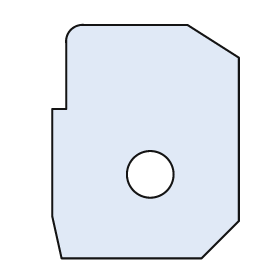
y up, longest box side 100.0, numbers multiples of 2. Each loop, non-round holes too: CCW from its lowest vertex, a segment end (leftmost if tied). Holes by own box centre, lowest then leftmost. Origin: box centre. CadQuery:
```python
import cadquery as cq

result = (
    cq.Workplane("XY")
    .moveTo(-36.0, -50.0)
    .lineTo(24.0, -50.0)
    .lineTo(40.0, -34.0)
    .lineTo(40.0, 36.0)
    .lineTo(18.0, 50.0)
    .lineTo(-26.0, 50.0)
    .threePointArc((-32.0, 48.0), (-34.0, 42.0))
    .lineTo(-34.0, 14.0)
    .lineTo(-40.0, 14.0)
    .lineTo(-40.0, -32.0)
    .close()
    .moveTo(2.0, -14.0)
    .circle(10.0)
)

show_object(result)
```